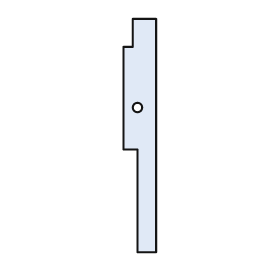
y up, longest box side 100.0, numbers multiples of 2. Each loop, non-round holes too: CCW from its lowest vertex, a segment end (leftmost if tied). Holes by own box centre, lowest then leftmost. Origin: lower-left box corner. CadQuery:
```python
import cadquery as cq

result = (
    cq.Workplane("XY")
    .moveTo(6.0, 0.0)
    .lineTo(14.0, 0.0)
    .lineTo(14.0, 100.0)
    .lineTo(4.0, 100.0)
    .lineTo(4.0, 88.0)
    .lineTo(0.0, 88.0)
    .lineTo(0.0, 44.0)
    .lineTo(6.0, 44.0)
    .close()
    .moveTo(6.0, 62.0)
    .circle(2.0)
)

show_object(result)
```